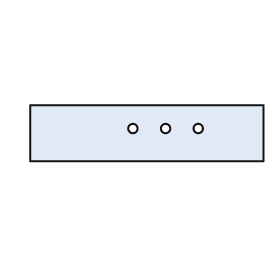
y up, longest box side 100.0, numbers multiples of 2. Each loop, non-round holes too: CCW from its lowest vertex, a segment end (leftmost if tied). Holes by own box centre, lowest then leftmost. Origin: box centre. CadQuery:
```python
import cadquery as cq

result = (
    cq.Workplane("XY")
    .moveTo(-50.0, -12.0)
    .lineTo(50.0, -12.0)
    .lineTo(50.0, 12.0)
    .lineTo(-50.0, 12.0)
    .close()
    .moveTo(-6.0, 2.0)
    .circle(2.0)
    .moveTo(8.0, 2.0)
    .circle(2.0)
    .moveTo(22.0, 2.0)
    .circle(2.0)
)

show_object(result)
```